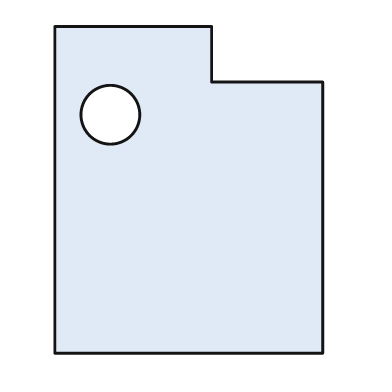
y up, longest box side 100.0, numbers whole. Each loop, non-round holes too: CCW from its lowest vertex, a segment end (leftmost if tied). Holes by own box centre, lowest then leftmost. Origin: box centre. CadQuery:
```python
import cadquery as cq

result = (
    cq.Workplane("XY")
    .moveTo(-41.0, -50.0)
    .lineTo(41.0, -50.0)
    .lineTo(41.0, 33.0)
    .lineTo(7.0, 33.0)
    .lineTo(7.0, 50.0)
    .lineTo(-41.0, 50.0)
    .close()
    .moveTo(-24.0, 23.0)
    .circle(9.0)
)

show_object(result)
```